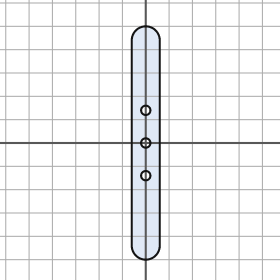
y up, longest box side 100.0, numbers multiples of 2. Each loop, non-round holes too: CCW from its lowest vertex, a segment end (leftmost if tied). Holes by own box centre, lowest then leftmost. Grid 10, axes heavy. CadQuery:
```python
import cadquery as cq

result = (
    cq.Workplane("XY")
    .moveTo(-6.0, -44.0)
    .threePointArc((0.0, -50.0), (6.0, -44.0))
    .lineTo(6.0, 44.0)
    .threePointArc((0.0, 50.0), (-6.0, 44.0))
    .close()
    .moveTo(0.0, -14.0)
    .circle(2.0)
    .moveTo(0.0, 0.0)
    .circle(2.0)
    .moveTo(0.0, 14.0)
    .circle(2.0)
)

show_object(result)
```